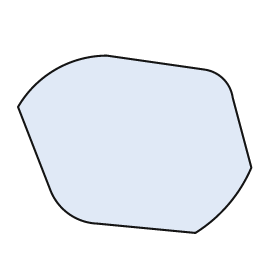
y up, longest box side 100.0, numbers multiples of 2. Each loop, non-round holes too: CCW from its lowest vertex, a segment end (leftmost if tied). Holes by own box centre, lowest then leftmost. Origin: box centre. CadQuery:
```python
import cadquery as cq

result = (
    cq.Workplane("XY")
    .moveTo(26.0, -38.0)
    .threePointArc((40.0, -26.0), (50.0, -10.0))
    .lineTo(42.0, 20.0)
    .threePointArc((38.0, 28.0), (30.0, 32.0))
    .lineTo(-12.0, 38.0)
    .threePointArc((-34.0, 32.0), (-50.0, 16.0))
    .lineTo(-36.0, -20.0)
    .threePointArc((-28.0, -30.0), (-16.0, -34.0))
    .close()
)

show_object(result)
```